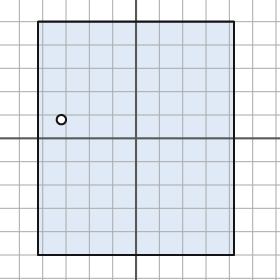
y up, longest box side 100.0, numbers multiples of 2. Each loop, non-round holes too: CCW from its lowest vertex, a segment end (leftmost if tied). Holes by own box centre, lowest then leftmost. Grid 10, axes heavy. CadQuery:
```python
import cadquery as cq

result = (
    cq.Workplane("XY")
    .moveTo(-42.0, -50.0)
    .lineTo(42.0, -50.0)
    .lineTo(42.0, 50.0)
    .lineTo(-42.0, 50.0)
    .close()
    .moveTo(-32.0, 8.0)
    .circle(2.0)
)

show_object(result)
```